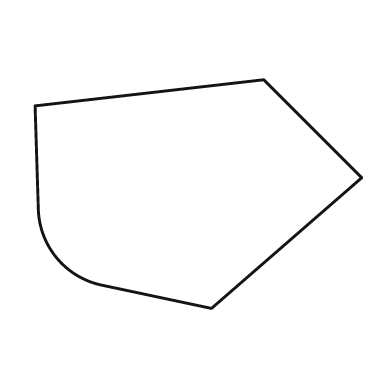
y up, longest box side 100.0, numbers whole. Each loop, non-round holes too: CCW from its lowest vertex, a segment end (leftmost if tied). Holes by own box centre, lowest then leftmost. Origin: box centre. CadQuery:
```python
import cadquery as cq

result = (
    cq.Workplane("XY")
    .moveTo(4.0, -35.0)
    .lineTo(50.0, 5.0)
    .lineTo(20.0, 35.0)
    .lineTo(-50.0, 27.0)
    .lineTo(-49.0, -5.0)
    .threePointArc((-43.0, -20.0), (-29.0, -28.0))
    .close()
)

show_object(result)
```